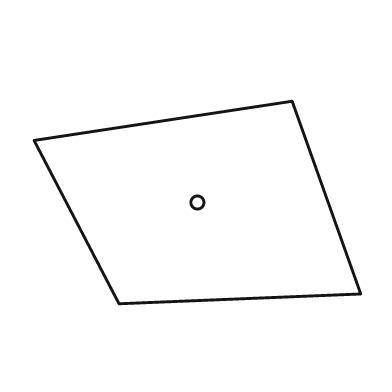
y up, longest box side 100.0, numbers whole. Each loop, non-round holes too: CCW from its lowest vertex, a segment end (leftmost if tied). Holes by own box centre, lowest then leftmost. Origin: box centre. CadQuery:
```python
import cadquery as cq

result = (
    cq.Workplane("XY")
    .moveTo(-24.0, -31.0)
    .lineTo(50.0, -28.0)
    .lineTo(29.0, 31.0)
    .lineTo(-50.0, 19.0)
    .close()
    .moveTo(0.0, 0.0)
    .circle(2.0)
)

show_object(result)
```